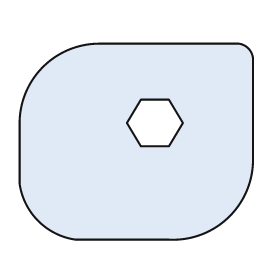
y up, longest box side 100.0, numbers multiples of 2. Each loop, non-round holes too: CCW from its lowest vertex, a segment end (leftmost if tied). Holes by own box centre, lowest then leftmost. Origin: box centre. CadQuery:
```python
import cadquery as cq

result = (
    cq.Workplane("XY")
    .moveTo(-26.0, -42.0)
    .lineTo(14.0, -42.0)
    .threePointArc((40.0, -32.0), (50.0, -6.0))
    .lineTo(50.0, 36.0)
    .threePointArc((48.0, 40.0), (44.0, 42.0))
    .lineTo(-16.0, 42.0)
    .threePointArc((-40.0, 32.0), (-50.0, 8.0))
    .lineTo(-50.0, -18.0)
    .threePointArc((-42.0, -34.0), (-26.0, -42.0))
    .close()
    .moveTo(2.0, -2.0)
    .lineTo(14.0, -2.0)
    .lineTo(20.0, 8.0)
    .lineTo(14.0, 18.0)
    .lineTo(2.0, 18.0)
    .lineTo(-4.0, 8.0)
    .close()
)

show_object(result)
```